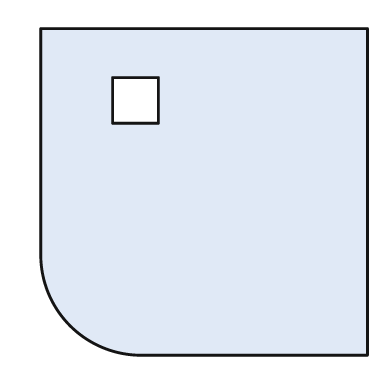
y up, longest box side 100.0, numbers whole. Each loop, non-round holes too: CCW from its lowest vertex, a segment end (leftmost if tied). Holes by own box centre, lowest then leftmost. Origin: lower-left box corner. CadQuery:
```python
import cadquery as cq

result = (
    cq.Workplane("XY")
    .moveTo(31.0, 0.0)
    .lineTo(100.0, 0.0)
    .lineTo(100.0, 100.0)
    .lineTo(0.0, 100.0)
    .lineTo(0.0, 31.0)
    .threePointArc((9.0, 9.0), (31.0, 0.0))
    .close()
    .moveTo(22.0, 71.0)
    .lineTo(36.0, 71.0)
    .lineTo(36.0, 85.0)
    .lineTo(22.0, 85.0)
    .close()
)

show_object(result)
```